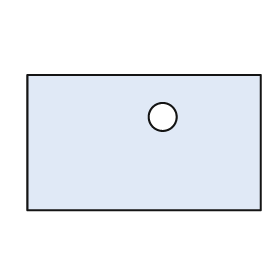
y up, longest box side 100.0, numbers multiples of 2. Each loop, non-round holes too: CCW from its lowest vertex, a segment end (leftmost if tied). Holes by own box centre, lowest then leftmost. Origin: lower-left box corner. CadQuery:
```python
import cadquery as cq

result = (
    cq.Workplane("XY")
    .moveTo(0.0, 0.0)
    .lineTo(100.0, 0.0)
    .lineTo(100.0, 58.0)
    .lineTo(0.0, 58.0)
    .close()
    .moveTo(58.0, 40.0)
    .circle(6.0)
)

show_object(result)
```